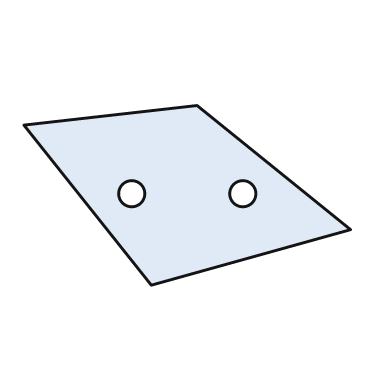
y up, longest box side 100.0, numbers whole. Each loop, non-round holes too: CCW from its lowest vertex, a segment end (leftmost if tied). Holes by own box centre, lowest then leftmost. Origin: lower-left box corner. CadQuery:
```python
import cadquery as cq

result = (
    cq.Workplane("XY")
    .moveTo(39.0, 0.0)
    .lineTo(100.0, 17.0)
    .lineTo(53.0, 55.0)
    .lineTo(0.0, 49.0)
    .close()
    .moveTo(33.0, 28.0)
    .circle(4.0)
    .moveTo(67.0, 28.0)
    .circle(4.0)
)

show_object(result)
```